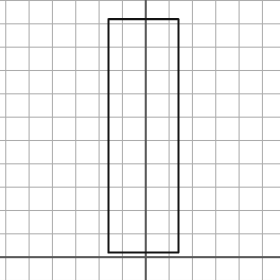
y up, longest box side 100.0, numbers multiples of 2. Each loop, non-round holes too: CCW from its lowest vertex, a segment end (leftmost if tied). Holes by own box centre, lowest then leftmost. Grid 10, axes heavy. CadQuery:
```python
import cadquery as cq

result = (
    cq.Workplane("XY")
    .moveTo(-16.0, 2.0)
    .lineTo(14.0, 2.0)
    .lineTo(14.0, 102.0)
    .lineTo(-16.0, 102.0)
    .close()
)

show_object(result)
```